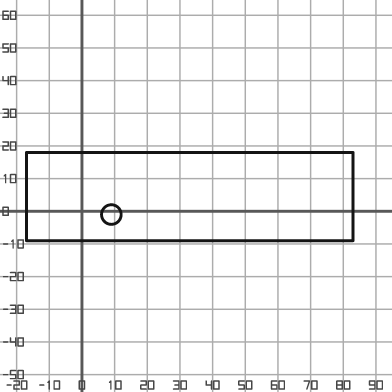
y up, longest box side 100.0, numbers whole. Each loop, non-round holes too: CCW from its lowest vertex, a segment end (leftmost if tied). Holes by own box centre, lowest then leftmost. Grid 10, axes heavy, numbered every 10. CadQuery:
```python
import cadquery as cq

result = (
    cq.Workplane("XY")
    .moveTo(-17.0, -9.0)
    .lineTo(83.0, -9.0)
    .lineTo(83.0, 18.0)
    .lineTo(-17.0, 18.0)
    .close()
    .moveTo(9.0, -1.0)
    .circle(3.0)
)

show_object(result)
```